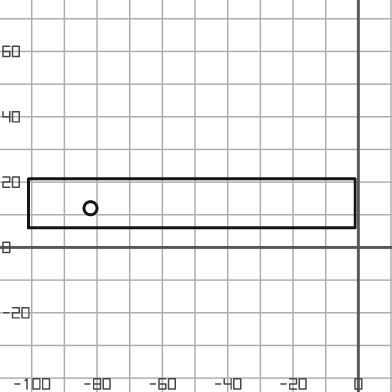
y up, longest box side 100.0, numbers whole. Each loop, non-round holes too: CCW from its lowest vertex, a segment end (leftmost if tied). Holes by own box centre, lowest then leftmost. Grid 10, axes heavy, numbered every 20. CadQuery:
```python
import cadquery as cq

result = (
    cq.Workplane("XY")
    .moveTo(-101.0, 6.0)
    .lineTo(-1.0, 6.0)
    .lineTo(-1.0, 21.0)
    .lineTo(-101.0, 21.0)
    .close()
    .moveTo(-82.0, 12.0)
    .circle(2.0)
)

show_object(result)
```